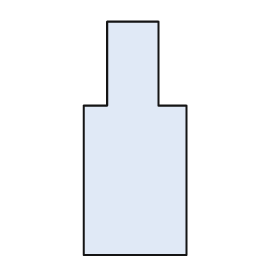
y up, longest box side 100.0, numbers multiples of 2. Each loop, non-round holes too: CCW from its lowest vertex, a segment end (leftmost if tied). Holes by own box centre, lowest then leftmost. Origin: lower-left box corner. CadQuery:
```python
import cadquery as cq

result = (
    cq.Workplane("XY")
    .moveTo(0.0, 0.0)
    .lineTo(44.0, 0.0)
    .lineTo(44.0, 64.0)
    .lineTo(32.0, 64.0)
    .lineTo(32.0, 100.0)
    .lineTo(10.0, 100.0)
    .lineTo(10.0, 64.0)
    .lineTo(0.0, 64.0)
    .close()
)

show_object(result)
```